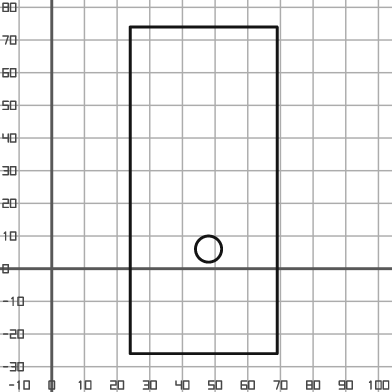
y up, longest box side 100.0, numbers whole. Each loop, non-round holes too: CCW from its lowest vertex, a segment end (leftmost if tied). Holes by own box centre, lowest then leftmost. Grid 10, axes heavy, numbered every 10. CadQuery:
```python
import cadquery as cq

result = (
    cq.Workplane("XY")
    .moveTo(24.0, -26.0)
    .lineTo(69.0, -26.0)
    .lineTo(69.0, 74.0)
    .lineTo(24.0, 74.0)
    .close()
    .moveTo(48.0, 6.0)
    .circle(4.0)
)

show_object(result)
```